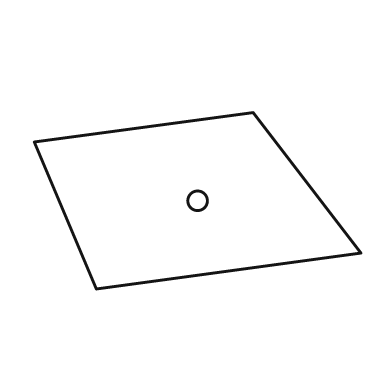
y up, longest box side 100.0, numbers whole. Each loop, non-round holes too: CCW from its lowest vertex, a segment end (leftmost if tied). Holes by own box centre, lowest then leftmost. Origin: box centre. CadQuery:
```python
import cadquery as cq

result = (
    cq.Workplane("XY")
    .moveTo(-31.0, -27.0)
    .lineTo(50.0, -16.0)
    .lineTo(17.0, 27.0)
    .lineTo(-50.0, 18.0)
    .close()
    .moveTo(0.0, 0.0)
    .circle(3.0)
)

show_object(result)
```